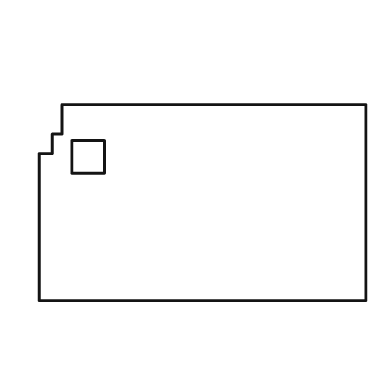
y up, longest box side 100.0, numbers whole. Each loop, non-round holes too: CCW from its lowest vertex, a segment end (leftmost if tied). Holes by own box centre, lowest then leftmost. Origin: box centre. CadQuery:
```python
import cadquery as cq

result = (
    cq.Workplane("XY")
    .moveTo(-50.0, -30.0)
    .lineTo(50.0, -30.0)
    .lineTo(50.0, 30.0)
    .lineTo(-43.0, 30.0)
    .lineTo(-43.0, 21.0)
    .lineTo(-46.0, 21.0)
    .lineTo(-46.0, 15.0)
    .lineTo(-50.0, 15.0)
    .close()
    .moveTo(-40.0, 9.0)
    .lineTo(-30.0, 9.0)
    .lineTo(-30.0, 19.0)
    .lineTo(-40.0, 19.0)
    .close()
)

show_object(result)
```